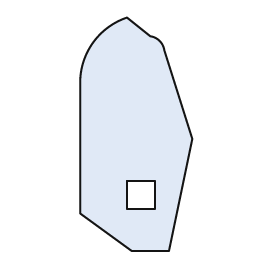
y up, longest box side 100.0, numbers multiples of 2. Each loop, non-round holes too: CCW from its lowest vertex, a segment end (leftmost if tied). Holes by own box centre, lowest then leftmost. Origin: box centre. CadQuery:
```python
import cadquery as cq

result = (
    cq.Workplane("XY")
    .moveTo(-2.0, -50.0)
    .lineTo(14.0, -50.0)
    .lineTo(24.0, -2.0)
    .lineTo(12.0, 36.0)
    .threePointArc((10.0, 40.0), (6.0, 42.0))
    .lineTo(-4.0, 50.0)
    .threePointArc((-18.0, 40.0), (-24.0, 24.0))
    .lineTo(-24.0, -34.0)
    .close()
    .moveTo(-4.0, -32.0)
    .lineTo(8.0, -32.0)
    .lineTo(8.0, -20.0)
    .lineTo(-4.0, -20.0)
    .close()
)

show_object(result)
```